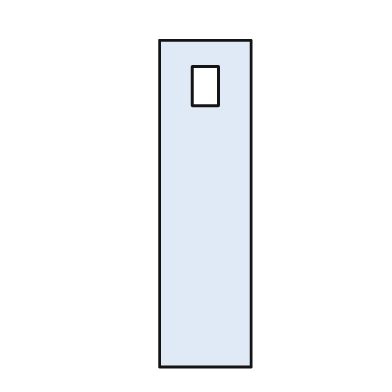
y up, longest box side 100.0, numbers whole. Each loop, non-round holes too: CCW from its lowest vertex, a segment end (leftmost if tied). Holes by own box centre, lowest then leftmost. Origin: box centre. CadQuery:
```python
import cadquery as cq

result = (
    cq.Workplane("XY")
    .moveTo(-14.0, -50.0)
    .lineTo(14.0, -50.0)
    .lineTo(14.0, 50.0)
    .lineTo(-14.0, 50.0)
    .close()
    .moveTo(-4.0, 30.0)
    .lineTo(4.0, 30.0)
    .lineTo(4.0, 42.0)
    .lineTo(-4.0, 42.0)
    .close()
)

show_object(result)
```